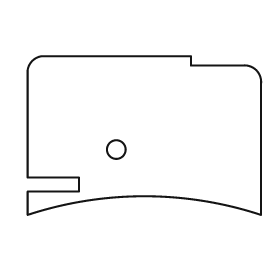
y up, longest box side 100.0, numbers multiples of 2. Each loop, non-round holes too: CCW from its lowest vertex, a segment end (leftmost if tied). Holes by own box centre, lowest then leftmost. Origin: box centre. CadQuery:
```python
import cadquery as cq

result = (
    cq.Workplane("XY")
    .moveTo(-50.0, -34.0)
    .threePointArc((0.0, -26.0), (50.0, -34.0))
    .lineTo(50.0, 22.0)
    .threePointArc((48.0, 28.0), (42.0, 30.0))
    .lineTo(20.0, 30.0)
    .lineTo(20.0, 34.0)
    .lineTo(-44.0, 34.0)
    .threePointArc((-48.0, 32.0), (-50.0, 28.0))
    .lineTo(-50.0, -18.0)
    .lineTo(-28.0, -18.0)
    .lineTo(-28.0, -24.0)
    .lineTo(-50.0, -24.0)
    .close()
    .moveTo(-12.0, -6.0)
    .circle(4.0)
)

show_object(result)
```